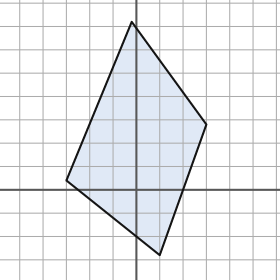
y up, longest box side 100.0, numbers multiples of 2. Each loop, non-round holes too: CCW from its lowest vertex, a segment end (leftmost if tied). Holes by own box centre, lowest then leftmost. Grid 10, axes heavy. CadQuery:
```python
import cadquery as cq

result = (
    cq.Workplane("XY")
    .moveTo(10.0, -28.0)
    .lineTo(30.0, 28.0)
    .lineTo(-2.0, 72.0)
    .lineTo(-30.0, 4.0)
    .close()
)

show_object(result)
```